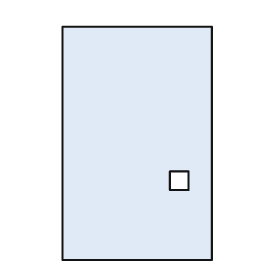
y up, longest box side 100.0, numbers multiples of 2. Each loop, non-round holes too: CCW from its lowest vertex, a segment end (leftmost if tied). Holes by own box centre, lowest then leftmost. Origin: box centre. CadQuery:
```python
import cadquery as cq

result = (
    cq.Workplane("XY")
    .moveTo(-32.0, -50.0)
    .lineTo(32.0, -50.0)
    .lineTo(32.0, 50.0)
    .lineTo(-32.0, 50.0)
    .close()
    .moveTo(14.0, -20.0)
    .lineTo(22.0, -20.0)
    .lineTo(22.0, -12.0)
    .lineTo(14.0, -12.0)
    .close()
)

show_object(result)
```